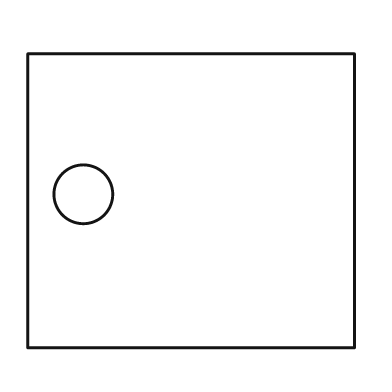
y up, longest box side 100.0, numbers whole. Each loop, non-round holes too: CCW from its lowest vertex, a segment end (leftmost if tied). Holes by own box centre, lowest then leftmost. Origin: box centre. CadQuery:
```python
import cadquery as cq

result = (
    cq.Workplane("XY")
    .moveTo(-50.0, -45.0)
    .lineTo(50.0, -45.0)
    .lineTo(50.0, 45.0)
    .lineTo(-50.0, 45.0)
    .close()
    .moveTo(-33.0, 2.0)
    .circle(9.0)
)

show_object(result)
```